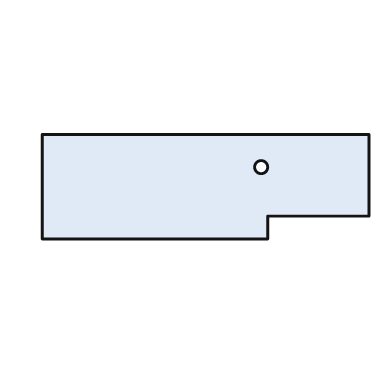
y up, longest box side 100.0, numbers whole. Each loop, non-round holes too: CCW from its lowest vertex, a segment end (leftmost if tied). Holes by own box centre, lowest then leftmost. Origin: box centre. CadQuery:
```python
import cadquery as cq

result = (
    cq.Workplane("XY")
    .moveTo(-50.0, -16.0)
    .lineTo(19.0, -16.0)
    .lineTo(19.0, -9.0)
    .lineTo(50.0, -9.0)
    .lineTo(50.0, 16.0)
    .lineTo(-50.0, 16.0)
    .close()
    .moveTo(17.0, 6.0)
    .circle(2.0)
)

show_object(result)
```